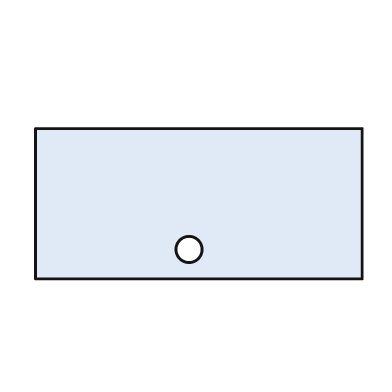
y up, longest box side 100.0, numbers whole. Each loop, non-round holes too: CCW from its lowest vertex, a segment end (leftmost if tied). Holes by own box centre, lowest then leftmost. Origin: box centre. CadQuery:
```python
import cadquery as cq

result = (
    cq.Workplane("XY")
    .moveTo(-50.0, -23.0)
    .lineTo(50.0, -23.0)
    .lineTo(50.0, 23.0)
    .lineTo(-50.0, 23.0)
    .close()
    .moveTo(-3.0, -14.0)
    .circle(4.0)
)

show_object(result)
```